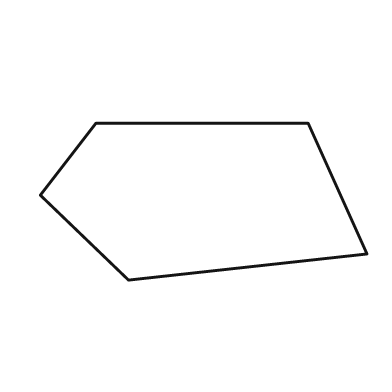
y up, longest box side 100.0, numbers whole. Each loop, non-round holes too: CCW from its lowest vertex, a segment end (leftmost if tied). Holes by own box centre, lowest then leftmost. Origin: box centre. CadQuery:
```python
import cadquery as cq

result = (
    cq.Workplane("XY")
    .moveTo(-23.0, -24.0)
    .lineTo(50.0, -16.0)
    .lineTo(32.0, 24.0)
    .lineTo(-33.0, 24.0)
    .lineTo(-50.0, 2.0)
    .close()
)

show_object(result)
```